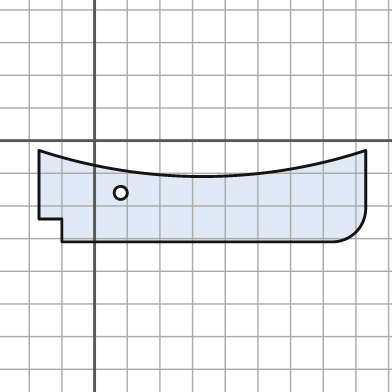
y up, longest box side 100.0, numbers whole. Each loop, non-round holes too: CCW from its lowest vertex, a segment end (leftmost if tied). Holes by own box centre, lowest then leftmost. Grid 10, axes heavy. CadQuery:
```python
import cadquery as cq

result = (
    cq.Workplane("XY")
    .moveTo(-10.0, -31.0)
    .lineTo(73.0, -31.0)
    .threePointArc((80.0, -28.0), (83.0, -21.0))
    .lineTo(83.0, -3.0)
    .threePointArc((33.0, -11.0), (-17.0, -3.0))
    .lineTo(-17.0, -24.0)
    .lineTo(-10.0, -24.0)
    .close()
    .moveTo(8.0, -16.0)
    .circle(2.0)
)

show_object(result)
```